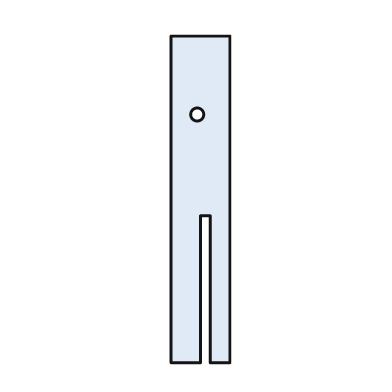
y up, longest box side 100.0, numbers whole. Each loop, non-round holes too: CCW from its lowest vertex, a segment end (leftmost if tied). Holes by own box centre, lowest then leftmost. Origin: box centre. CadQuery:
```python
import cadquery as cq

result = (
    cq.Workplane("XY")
    .moveTo(-9.0, -50.0)
    .lineTo(0.0, -50.0)
    .lineTo(0.0, -5.0)
    .lineTo(3.0, -5.0)
    .lineTo(3.0, -50.0)
    .lineTo(9.0, -50.0)
    .lineTo(9.0, 50.0)
    .lineTo(-9.0, 50.0)
    .close()
    .moveTo(-1.0, 26.0)
    .circle(2.0)
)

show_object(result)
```